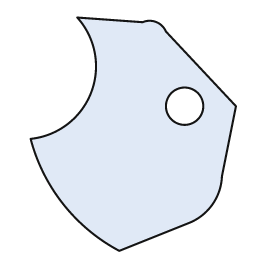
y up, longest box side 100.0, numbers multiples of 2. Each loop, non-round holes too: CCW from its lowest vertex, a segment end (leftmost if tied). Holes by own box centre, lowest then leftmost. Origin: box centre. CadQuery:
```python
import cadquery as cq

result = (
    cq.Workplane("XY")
    .moveTo(-6.0, -50.0)
    .lineTo(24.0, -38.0)
    .threePointArc((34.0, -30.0), (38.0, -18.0))
    .lineTo(44.0, 12.0)
    .lineTo(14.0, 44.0)
    .threePointArc((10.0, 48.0), (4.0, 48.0))
    .lineTo(-24.0, 50.0)
    .threePointArc((-18.0, 18.0), (-44.0, -2.0))
    .threePointArc((-30.0, -30.0), (-6.0, -50.0))
    .close()
    .moveTo(22.0, 12.0)
    .circle(8.0)
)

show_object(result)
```